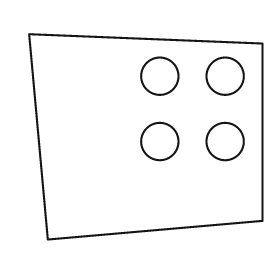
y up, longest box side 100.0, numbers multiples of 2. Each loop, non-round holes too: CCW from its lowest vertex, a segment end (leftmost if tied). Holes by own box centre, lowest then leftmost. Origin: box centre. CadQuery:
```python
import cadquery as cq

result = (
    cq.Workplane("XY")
    .moveTo(-42.0, -44.0)
    .lineTo(50.0, -36.0)
    .lineTo(50.0, 40.0)
    .lineTo(-50.0, 44.0)
    .close()
    .moveTo(6.0, -2.0)
    .circle(8.0)
    .moveTo(34.0, -2.0)
    .circle(8.0)
    .moveTo(6.0, 26.0)
    .circle(8.0)
    .moveTo(34.0, 26.0)
    .circle(8.0)
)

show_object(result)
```